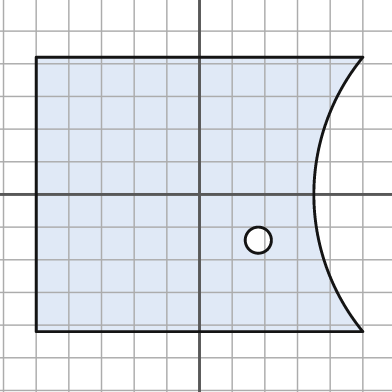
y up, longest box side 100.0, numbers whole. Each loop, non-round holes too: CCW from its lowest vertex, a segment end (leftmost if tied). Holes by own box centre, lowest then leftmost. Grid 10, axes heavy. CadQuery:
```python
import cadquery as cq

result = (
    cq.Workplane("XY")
    .moveTo(-50.0, -42.0)
    .lineTo(50.0, -42.0)
    .threePointArc((35.0, 0.0), (50.0, 42.0))
    .lineTo(-50.0, 42.0)
    .close()
    .moveTo(18.0, -14.0)
    .circle(4.0)
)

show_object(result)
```